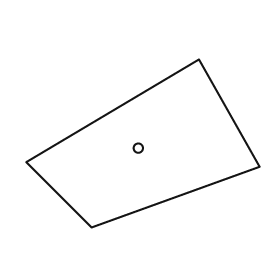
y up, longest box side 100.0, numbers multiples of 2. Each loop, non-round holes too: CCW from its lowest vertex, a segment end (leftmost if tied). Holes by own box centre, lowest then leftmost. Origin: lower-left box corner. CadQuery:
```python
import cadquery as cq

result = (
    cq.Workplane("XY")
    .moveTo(28.0, 0.0)
    .lineTo(100.0, 26.0)
    .lineTo(74.0, 72.0)
    .lineTo(0.0, 28.0)
    .close()
    .moveTo(48.0, 34.0)
    .circle(2.0)
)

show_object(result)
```